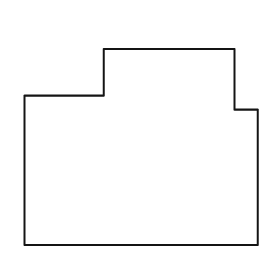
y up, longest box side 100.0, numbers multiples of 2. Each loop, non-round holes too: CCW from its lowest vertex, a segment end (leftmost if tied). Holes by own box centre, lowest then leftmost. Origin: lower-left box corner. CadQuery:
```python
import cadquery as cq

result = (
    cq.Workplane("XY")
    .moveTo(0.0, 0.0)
    .lineTo(100.0, 0.0)
    .lineTo(100.0, 58.0)
    .lineTo(90.0, 58.0)
    .lineTo(90.0, 84.0)
    .lineTo(34.0, 84.0)
    .lineTo(34.0, 64.0)
    .lineTo(0.0, 64.0)
    .close()
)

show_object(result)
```